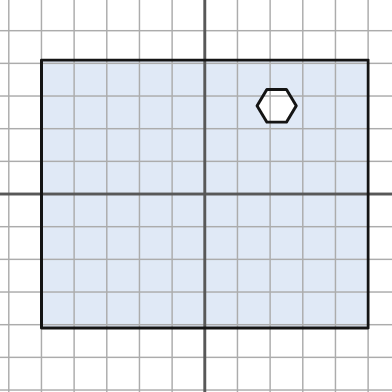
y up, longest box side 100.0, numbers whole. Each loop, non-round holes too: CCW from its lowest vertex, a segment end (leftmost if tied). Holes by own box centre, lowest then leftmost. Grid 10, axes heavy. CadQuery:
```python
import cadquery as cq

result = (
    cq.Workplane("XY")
    .moveTo(-50.0, -41.0)
    .lineTo(50.0, -41.0)
    .lineTo(50.0, 41.0)
    .lineTo(-50.0, 41.0)
    .close()
    .moveTo(19.0, 22.0)
    .lineTo(25.0, 22.0)
    .lineTo(28.0, 27.0)
    .lineTo(25.0, 32.0)
    .lineTo(19.0, 32.0)
    .lineTo(16.0, 27.0)
    .close()
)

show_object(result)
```